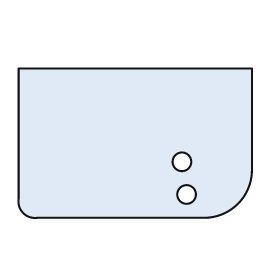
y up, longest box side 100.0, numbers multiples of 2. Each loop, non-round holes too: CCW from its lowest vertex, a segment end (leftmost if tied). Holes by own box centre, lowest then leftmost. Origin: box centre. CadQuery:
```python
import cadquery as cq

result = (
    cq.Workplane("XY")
    .moveTo(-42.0, -32.0)
    .lineTo(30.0, -32.0)
    .threePointArc((44.0, -26.0), (50.0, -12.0))
    .lineTo(50.0, 32.0)
    .lineTo(-50.0, 32.0)
    .lineTo(-50.0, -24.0)
    .threePointArc((-48.0, -30.0), (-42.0, -32.0))
    .close()
    .moveTo(22.0, -22.0)
    .circle(4.0)
    .moveTo(20.0, -8.0)
    .circle(4.0)
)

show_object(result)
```